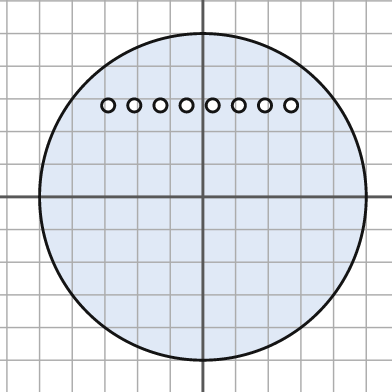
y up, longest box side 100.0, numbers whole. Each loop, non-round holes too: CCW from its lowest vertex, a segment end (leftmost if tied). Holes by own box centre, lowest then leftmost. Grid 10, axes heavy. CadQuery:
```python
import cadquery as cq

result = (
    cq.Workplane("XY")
    .moveTo(0.0, 0.0)
    .circle(50.0)
    .moveTo(-29.0, 28.0)
    .circle(2.0)
    .moveTo(-21.0, 28.0)
    .circle(2.0)
    .moveTo(-13.0, 28.0)
    .circle(2.0)
    .moveTo(-5.0, 28.0)
    .circle(2.0)
    .moveTo(3.0, 28.0)
    .circle(2.0)
    .moveTo(11.0, 28.0)
    .circle(2.0)
    .moveTo(19.0, 28.0)
    .circle(2.0)
    .moveTo(27.0, 28.0)
    .circle(2.0)
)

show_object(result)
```